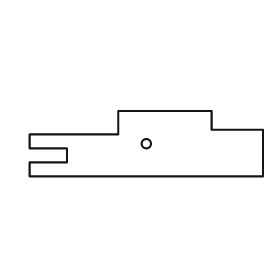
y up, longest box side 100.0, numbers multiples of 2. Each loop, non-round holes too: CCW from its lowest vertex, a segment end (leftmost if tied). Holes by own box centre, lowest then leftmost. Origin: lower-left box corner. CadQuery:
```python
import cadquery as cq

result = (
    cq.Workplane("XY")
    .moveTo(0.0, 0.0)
    .lineTo(100.0, 0.0)
    .lineTo(100.0, 20.0)
    .lineTo(78.0, 20.0)
    .lineTo(78.0, 28.0)
    .lineTo(38.0, 28.0)
    .lineTo(38.0, 18.0)
    .lineTo(0.0, 18.0)
    .lineTo(0.0, 12.0)
    .lineTo(16.0, 12.0)
    .lineTo(16.0, 6.0)
    .lineTo(0.0, 6.0)
    .close()
    .moveTo(50.0, 14.0)
    .circle(2.0)
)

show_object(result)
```